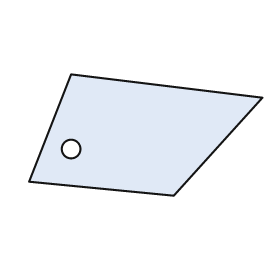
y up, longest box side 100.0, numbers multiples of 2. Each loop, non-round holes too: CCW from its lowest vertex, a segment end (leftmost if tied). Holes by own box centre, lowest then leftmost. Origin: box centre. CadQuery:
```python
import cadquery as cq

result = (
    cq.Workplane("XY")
    .moveTo(12.0, -26.0)
    .lineTo(50.0, 16.0)
    .lineTo(-32.0, 26.0)
    .lineTo(-50.0, -20.0)
    .close()
    .moveTo(-32.0, -6.0)
    .circle(4.0)
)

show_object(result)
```